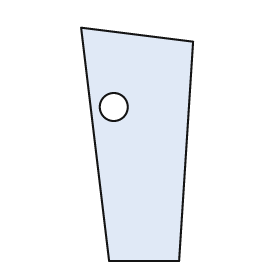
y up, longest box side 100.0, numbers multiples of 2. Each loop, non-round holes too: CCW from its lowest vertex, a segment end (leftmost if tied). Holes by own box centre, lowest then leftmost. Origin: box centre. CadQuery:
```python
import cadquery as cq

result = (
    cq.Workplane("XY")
    .moveTo(-12.0, -50.0)
    .lineTo(18.0, -50.0)
    .lineTo(24.0, 44.0)
    .lineTo(-24.0, 50.0)
    .close()
    .moveTo(-10.0, 16.0)
    .circle(6.0)
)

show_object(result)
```